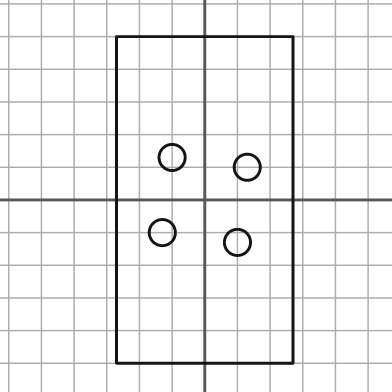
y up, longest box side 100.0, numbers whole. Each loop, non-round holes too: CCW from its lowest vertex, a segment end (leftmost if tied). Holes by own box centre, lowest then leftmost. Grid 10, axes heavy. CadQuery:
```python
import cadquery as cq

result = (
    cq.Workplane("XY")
    .moveTo(-27.0, -50.0)
    .lineTo(27.0, -50.0)
    .lineTo(27.0, 50.0)
    .lineTo(-27.0, 50.0)
    .close()
    .moveTo(10.0, -13.0)
    .circle(4.0)
    .moveTo(-13.0, -10.0)
    .circle(4.0)
    .moveTo(13.0, 10.0)
    .circle(4.0)
    .moveTo(-10.0, 13.0)
    .circle(4.0)
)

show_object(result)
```